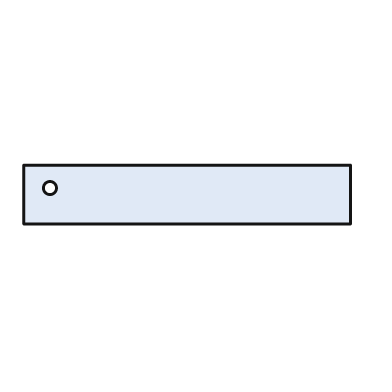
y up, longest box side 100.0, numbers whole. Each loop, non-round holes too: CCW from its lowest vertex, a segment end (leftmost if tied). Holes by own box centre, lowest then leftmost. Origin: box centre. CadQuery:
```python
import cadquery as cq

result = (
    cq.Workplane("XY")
    .moveTo(-50.0, -9.0)
    .lineTo(50.0, -9.0)
    .lineTo(50.0, 9.0)
    .lineTo(-50.0, 9.0)
    .close()
    .moveTo(-42.0, 2.0)
    .circle(2.0)
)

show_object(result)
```